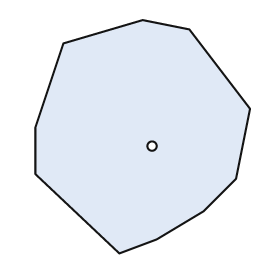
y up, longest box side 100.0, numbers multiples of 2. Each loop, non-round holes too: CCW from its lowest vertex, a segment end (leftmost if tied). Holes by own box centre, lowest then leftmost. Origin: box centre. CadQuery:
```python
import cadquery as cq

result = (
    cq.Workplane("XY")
    .moveTo(-10.0, -50.0)
    .lineTo(6.0, -44.0)
    .lineTo(26.0, -32.0)
    .lineTo(40.0, -18.0)
    .lineTo(46.0, 12.0)
    .lineTo(20.0, 46.0)
    .lineTo(0.0, 50.0)
    .lineTo(-34.0, 40.0)
    .lineTo(-46.0, 4.0)
    .lineTo(-46.0, -16.0)
    .close()
    .moveTo(4.0, -4.0)
    .circle(2.0)
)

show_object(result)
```